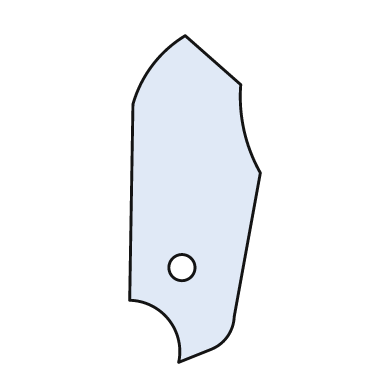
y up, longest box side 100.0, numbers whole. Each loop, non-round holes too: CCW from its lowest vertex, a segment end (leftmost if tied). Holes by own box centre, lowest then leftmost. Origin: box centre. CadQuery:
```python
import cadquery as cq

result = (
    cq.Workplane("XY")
    .moveTo(-5.0, -50.0)
    .lineTo(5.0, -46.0)
    .threePointArc((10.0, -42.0), (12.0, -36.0))
    .lineTo(20.0, 8.0)
    .threePointArc((15.0, 21.0), (14.0, 35.0))
    .lineTo(-3.0, 50.0)
    .threePointArc((-13.0, 41.0), (-19.0, 29.0))
    .lineTo(-20.0, -31.0)
    .threePointArc((-8.0, -37.0), (-5.0, -50.0))
    .close()
    .moveTo(-4.0, -21.0)
    .circle(4.0)
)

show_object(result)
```